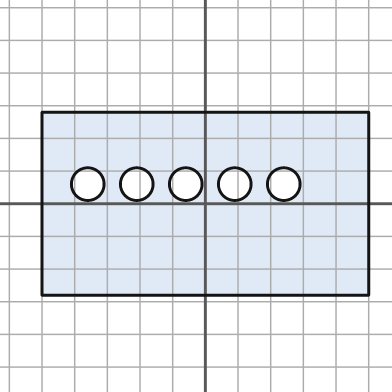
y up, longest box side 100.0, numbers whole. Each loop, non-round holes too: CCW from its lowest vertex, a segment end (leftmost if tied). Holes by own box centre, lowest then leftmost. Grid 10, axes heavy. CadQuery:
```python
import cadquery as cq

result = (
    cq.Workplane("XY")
    .moveTo(-50.0, -28.0)
    .lineTo(50.0, -28.0)
    .lineTo(50.0, 28.0)
    .lineTo(-50.0, 28.0)
    .close()
    .moveTo(-36.0, 6.0)
    .circle(5.0)
    .moveTo(-21.0, 6.0)
    .circle(5.0)
    .moveTo(-6.0, 6.0)
    .circle(5.0)
    .moveTo(9.0, 6.0)
    .circle(5.0)
    .moveTo(24.0, 6.0)
    .circle(5.0)
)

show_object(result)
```